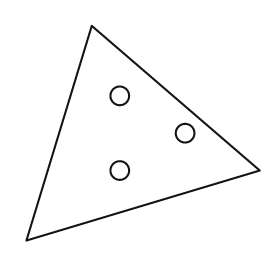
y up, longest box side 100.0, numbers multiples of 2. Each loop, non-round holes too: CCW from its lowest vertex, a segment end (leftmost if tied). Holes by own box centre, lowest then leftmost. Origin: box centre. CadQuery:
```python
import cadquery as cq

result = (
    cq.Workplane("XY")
    .moveTo(-50.0, -46.0)
    .lineTo(50.0, -16.0)
    .lineTo(-22.0, 46.0)
    .close()
    .moveTo(-10.0, -16.0)
    .circle(4.0)
    .moveTo(18.0, 0.0)
    .circle(4.0)
    .moveTo(-10.0, 16.0)
    .circle(4.0)
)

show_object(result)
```